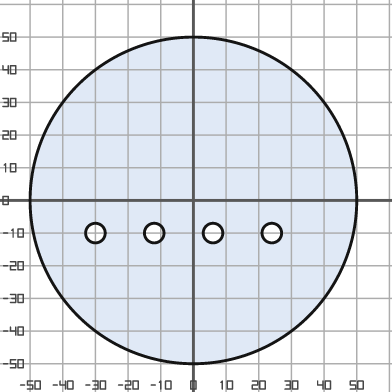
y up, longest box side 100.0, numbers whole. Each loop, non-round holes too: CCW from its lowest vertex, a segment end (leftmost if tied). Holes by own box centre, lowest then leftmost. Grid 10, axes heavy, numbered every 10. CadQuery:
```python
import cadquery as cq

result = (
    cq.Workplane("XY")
    .moveTo(0.0, 0.0)
    .circle(50.0)
    .moveTo(-30.0, -10.0)
    .circle(3.0)
    .moveTo(-12.0, -10.0)
    .circle(3.0)
    .moveTo(6.0, -10.0)
    .circle(3.0)
    .moveTo(24.0, -10.0)
    .circle(3.0)
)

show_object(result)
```